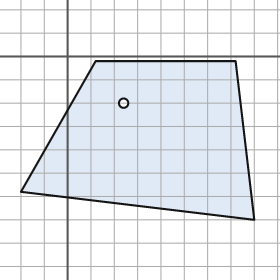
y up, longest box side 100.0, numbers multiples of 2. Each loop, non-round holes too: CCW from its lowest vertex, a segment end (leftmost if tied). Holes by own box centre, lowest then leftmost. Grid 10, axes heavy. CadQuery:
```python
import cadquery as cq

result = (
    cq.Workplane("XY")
    .moveTo(80.0, -70.0)
    .lineTo(72.0, -2.0)
    .lineTo(12.0, -2.0)
    .lineTo(-20.0, -58.0)
    .close()
    .moveTo(24.0, -20.0)
    .circle(2.0)
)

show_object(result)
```